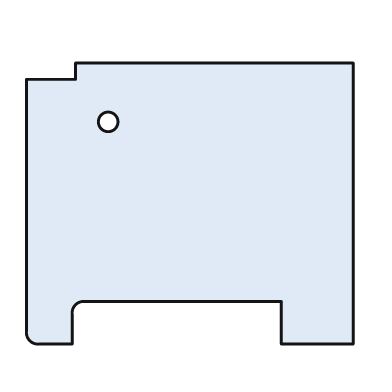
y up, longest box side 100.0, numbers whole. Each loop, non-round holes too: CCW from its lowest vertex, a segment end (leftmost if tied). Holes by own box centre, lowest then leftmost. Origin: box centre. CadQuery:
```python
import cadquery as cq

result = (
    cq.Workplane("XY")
    .moveTo(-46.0, -43.0)
    .lineTo(-36.0, -43.0)
    .lineTo(-36.0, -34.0)
    .threePointArc((-35.0, -31.0), (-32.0, -30.0))
    .lineTo(28.0, -30.0)
    .lineTo(28.0, -43.0)
    .lineTo(50.0, -43.0)
    .lineTo(50.0, 43.0)
    .lineTo(-35.0, 43.0)
    .lineTo(-35.0, 38.0)
    .lineTo(-50.0, 38.0)
    .lineTo(-50.0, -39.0)
    .threePointArc((-49.0, -42.0), (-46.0, -43.0))
    .close()
    .moveTo(-25.0, 25.0)
    .circle(3.0)
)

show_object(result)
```